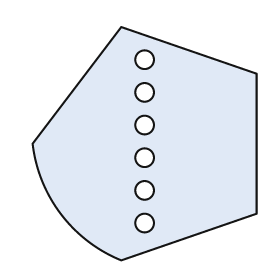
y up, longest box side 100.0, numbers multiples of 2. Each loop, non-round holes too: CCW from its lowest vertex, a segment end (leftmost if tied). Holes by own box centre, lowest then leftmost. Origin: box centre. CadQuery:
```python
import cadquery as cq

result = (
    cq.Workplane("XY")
    .moveTo(-10.0, -50.0)
    .lineTo(48.0, -30.0)
    .lineTo(48.0, 30.0)
    .lineTo(-10.0, 50.0)
    .lineTo(-48.0, 0.0)
    .threePointArc((-36.0, -30.0), (-10.0, -50.0))
    .close()
    .moveTo(0.0, -34.0)
    .circle(4.0)
    .moveTo(0.0, -20.0)
    .circle(4.0)
    .moveTo(0.0, -6.0)
    .circle(4.0)
    .moveTo(0.0, 8.0)
    .circle(4.0)
    .moveTo(0.0, 22.0)
    .circle(4.0)
    .moveTo(0.0, 36.0)
    .circle(4.0)
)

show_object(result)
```